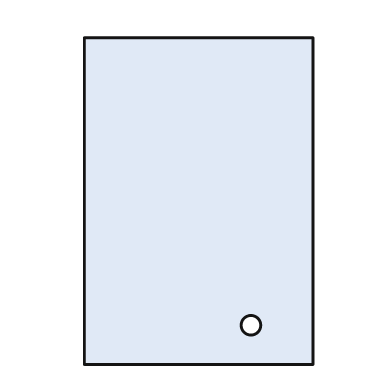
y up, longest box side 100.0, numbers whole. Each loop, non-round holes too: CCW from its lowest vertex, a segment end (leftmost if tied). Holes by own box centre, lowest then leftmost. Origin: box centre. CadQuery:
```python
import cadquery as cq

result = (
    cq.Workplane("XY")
    .moveTo(-35.0, -50.0)
    .lineTo(35.0, -50.0)
    .lineTo(35.0, 50.0)
    .lineTo(-35.0, 50.0)
    .close()
    .moveTo(16.0, -38.0)
    .circle(3.0)
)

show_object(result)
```